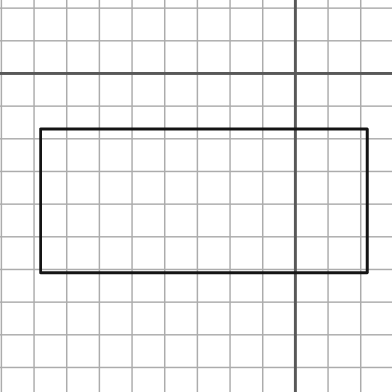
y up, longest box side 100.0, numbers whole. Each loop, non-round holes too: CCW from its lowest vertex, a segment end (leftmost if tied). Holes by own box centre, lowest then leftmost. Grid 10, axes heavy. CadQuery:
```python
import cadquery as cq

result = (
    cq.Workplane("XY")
    .moveTo(-78.0, -61.0)
    .lineTo(22.0, -61.0)
    .lineTo(22.0, -17.0)
    .lineTo(-78.0, -17.0)
    .close()
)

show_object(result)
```